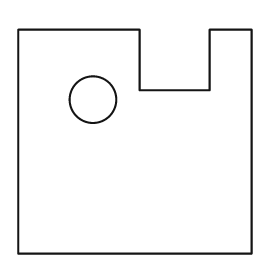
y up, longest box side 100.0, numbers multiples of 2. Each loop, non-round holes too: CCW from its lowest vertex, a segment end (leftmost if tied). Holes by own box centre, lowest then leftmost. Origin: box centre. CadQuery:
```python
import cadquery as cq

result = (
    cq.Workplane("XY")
    .moveTo(-50.0, -48.0)
    .lineTo(50.0, -48.0)
    .lineTo(50.0, 48.0)
    .lineTo(32.0, 48.0)
    .lineTo(32.0, 22.0)
    .lineTo(2.0, 22.0)
    .lineTo(2.0, 48.0)
    .lineTo(-50.0, 48.0)
    .close()
    .moveTo(-18.0, 18.0)
    .circle(10.0)
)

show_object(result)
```